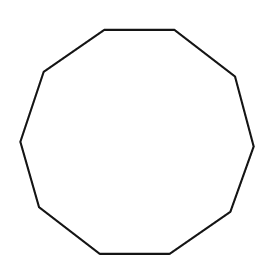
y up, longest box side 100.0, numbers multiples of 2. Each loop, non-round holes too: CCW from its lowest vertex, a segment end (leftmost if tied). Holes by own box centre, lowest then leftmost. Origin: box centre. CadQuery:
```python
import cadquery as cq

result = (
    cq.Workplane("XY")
    .moveTo(-16.0, -48.0)
    .lineTo(14.0, -48.0)
    .lineTo(40.0, -30.0)
    .lineTo(50.0, -2.0)
    .lineTo(42.0, 28.0)
    .lineTo(16.0, 48.0)
    .lineTo(-14.0, 48.0)
    .lineTo(-40.0, 30.0)
    .lineTo(-50.0, 0.0)
    .lineTo(-42.0, -28.0)
    .close()
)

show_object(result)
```